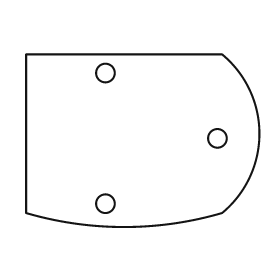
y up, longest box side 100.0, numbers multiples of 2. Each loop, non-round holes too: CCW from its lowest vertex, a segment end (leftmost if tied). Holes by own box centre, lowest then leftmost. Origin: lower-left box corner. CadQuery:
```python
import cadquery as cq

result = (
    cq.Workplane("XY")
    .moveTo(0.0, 6.0)
    .threePointArc((42.0, 0.0), (84.0, 6.0))
    .threePointArc((100.0, 40.0), (84.0, 74.0))
    .lineTo(0.0, 74.0)
    .close()
    .moveTo(34.0, 10.0)
    .circle(4.0)
    .moveTo(82.0, 38.0)
    .circle(4.0)
    .moveTo(34.0, 66.0)
    .circle(4.0)
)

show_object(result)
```